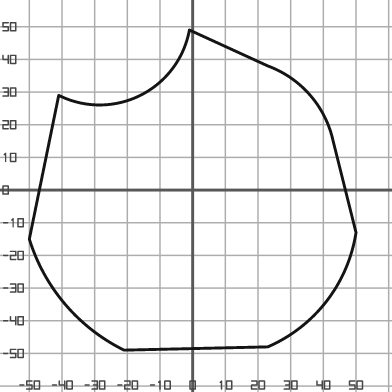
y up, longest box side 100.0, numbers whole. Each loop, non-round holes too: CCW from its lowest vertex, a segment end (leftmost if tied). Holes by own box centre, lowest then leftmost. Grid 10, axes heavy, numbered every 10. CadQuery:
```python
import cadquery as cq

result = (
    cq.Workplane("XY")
    .moveTo(-21.0, -49.0)
    .lineTo(23.0, -48.0)
    .threePointArc((41.0, -34.0), (50.0, -13.0))
    .lineTo(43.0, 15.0)
    .threePointArc((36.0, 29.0), (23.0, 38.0))
    .lineTo(-1.0, 49.0)
    .threePointArc((-16.0, 29.0), (-41.0, 29.0))
    .lineTo(-50.0, -15.0)
    .threePointArc((-39.0, -35.0), (-21.0, -49.0))
    .close()
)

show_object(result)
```